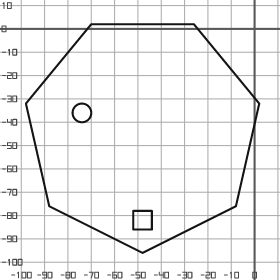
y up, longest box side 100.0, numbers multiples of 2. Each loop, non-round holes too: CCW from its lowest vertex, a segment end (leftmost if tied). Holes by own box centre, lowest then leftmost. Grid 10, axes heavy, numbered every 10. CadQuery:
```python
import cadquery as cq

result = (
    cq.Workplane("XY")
    .moveTo(-48.0, -96.0)
    .lineTo(-8.0, -76.0)
    .lineTo(2.0, -32.0)
    .lineTo(-26.0, 2.0)
    .lineTo(-70.0, 2.0)
    .lineTo(-98.0, -32.0)
    .lineTo(-88.0, -76.0)
    .close()
    .moveTo(-52.0, -86.0)
    .lineTo(-44.0, -86.0)
    .lineTo(-44.0, -78.0)
    .lineTo(-52.0, -78.0)
    .close()
    .moveTo(-74.0, -36.0)
    .circle(4.0)
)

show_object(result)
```